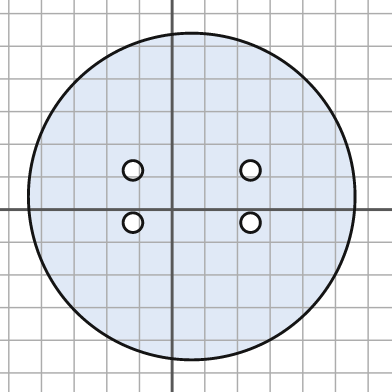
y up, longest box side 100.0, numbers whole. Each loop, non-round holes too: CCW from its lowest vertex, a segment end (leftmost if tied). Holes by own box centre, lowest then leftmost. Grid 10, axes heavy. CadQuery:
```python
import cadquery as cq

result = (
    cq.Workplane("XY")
    .moveTo(6.0, 4.0)
    .circle(50.0)
    .moveTo(-12.0, -4.0)
    .circle(3.0)
    .moveTo(24.0, -4.0)
    .circle(3.0)
    .moveTo(-12.0, 12.0)
    .circle(3.0)
    .moveTo(24.0, 12.0)
    .circle(3.0)
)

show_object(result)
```